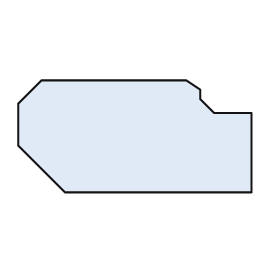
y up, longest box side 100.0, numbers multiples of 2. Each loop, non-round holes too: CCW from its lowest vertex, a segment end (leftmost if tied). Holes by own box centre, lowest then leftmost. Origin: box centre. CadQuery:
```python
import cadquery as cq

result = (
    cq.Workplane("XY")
    .moveTo(-30.0, -24.0)
    .lineTo(50.0, -24.0)
    .lineTo(50.0, 10.0)
    .lineTo(34.0, 10.0)
    .lineTo(28.0, 16.0)
    .lineTo(28.0, 20.0)
    .lineTo(22.0, 24.0)
    .lineTo(-40.0, 24.0)
    .lineTo(-50.0, 14.0)
    .lineTo(-50.0, -4.0)
    .close()
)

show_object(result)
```